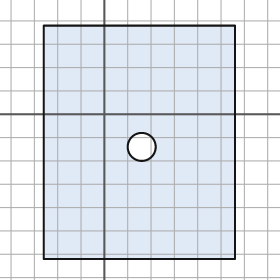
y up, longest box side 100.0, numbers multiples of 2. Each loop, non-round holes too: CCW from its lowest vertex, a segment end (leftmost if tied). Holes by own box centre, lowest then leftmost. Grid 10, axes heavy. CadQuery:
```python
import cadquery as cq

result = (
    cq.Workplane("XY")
    .moveTo(-26.0, -62.0)
    .lineTo(56.0, -62.0)
    .lineTo(56.0, 38.0)
    .lineTo(-26.0, 38.0)
    .close()
    .moveTo(16.0, -14.0)
    .circle(6.0)
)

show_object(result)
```